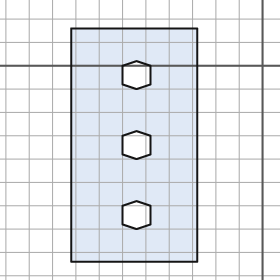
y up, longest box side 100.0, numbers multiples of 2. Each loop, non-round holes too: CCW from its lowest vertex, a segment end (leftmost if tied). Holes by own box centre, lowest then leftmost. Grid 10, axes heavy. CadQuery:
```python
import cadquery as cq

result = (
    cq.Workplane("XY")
    .moveTo(-82.0, -84.0)
    .lineTo(-28.0, -84.0)
    .lineTo(-28.0, 16.0)
    .lineTo(-82.0, 16.0)
    .close()
    .moveTo(-54.0, -70.0)
    .lineTo(-48.0, -68.0)
    .lineTo(-48.0, -60.0)
    .lineTo(-54.0, -58.0)
    .lineTo(-60.0, -60.0)
    .lineTo(-60.0, -68.0)
    .close()
    .moveTo(-54.0, -40.0)
    .lineTo(-48.0, -38.0)
    .lineTo(-48.0, -30.0)
    .lineTo(-54.0, -28.0)
    .lineTo(-60.0, -30.0)
    .lineTo(-60.0, -38.0)
    .close()
    .moveTo(-54.0, -10.0)
    .lineTo(-48.0, -8.0)
    .lineTo(-48.0, 0.0)
    .lineTo(-54.0, 2.0)
    .lineTo(-60.0, 0.0)
    .lineTo(-60.0, -8.0)
    .close()
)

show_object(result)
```